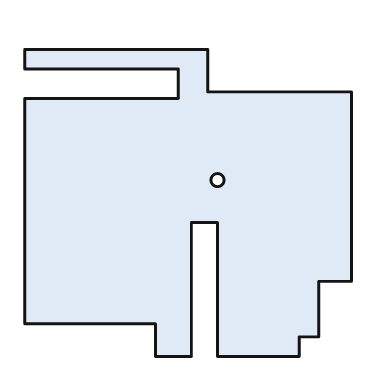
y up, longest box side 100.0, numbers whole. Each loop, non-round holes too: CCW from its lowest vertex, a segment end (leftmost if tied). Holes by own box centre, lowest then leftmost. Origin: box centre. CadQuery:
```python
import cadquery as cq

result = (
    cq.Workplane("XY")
    .moveTo(-10.0, -47.0)
    .lineTo(1.0, -47.0)
    .lineTo(1.0, -6.0)
    .lineTo(9.0, -6.0)
    .lineTo(9.0, -47.0)
    .lineTo(34.0, -47.0)
    .lineTo(34.0, -41.0)
    .lineTo(40.0, -41.0)
    .lineTo(40.0, -24.0)
    .lineTo(50.0, -24.0)
    .lineTo(50.0, 34.0)
    .lineTo(6.0, 34.0)
    .lineTo(6.0, 47.0)
    .lineTo(-50.0, 47.0)
    .lineTo(-50.0, 41.0)
    .lineTo(-3.0, 41.0)
    .lineTo(-3.0, 32.0)
    .lineTo(-50.0, 32.0)
    .lineTo(-50.0, -37.0)
    .lineTo(-10.0, -37.0)
    .close()
    .moveTo(9.0, 7.0)
    .circle(2.0)
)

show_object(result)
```